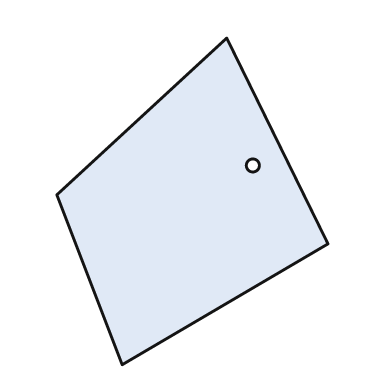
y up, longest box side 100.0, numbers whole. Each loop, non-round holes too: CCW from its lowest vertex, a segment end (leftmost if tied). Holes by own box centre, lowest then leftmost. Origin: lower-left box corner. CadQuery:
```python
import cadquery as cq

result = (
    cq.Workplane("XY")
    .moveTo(20.0, 0.0)
    .lineTo(83.0, 37.0)
    .lineTo(52.0, 100.0)
    .lineTo(0.0, 52.0)
    .close()
    .moveTo(60.0, 61.0)
    .circle(2.0)
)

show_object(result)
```